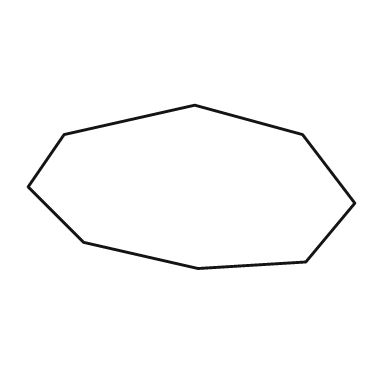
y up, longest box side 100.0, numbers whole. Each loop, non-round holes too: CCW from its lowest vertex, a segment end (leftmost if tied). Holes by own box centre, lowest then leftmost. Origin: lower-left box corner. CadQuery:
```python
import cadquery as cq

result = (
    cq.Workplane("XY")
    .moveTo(52.0, 0.0)
    .lineTo(85.0, 2.0)
    .lineTo(100.0, 20.0)
    .lineTo(84.0, 41.0)
    .lineTo(51.0, 50.0)
    .lineTo(11.0, 41.0)
    .lineTo(0.0, 25.0)
    .lineTo(17.0, 8.0)
    .close()
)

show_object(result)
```